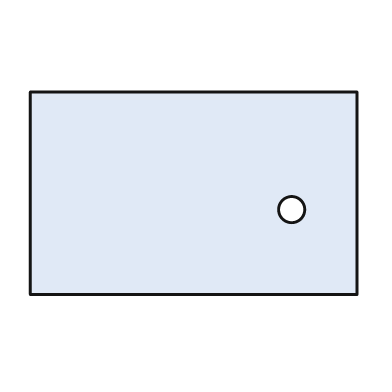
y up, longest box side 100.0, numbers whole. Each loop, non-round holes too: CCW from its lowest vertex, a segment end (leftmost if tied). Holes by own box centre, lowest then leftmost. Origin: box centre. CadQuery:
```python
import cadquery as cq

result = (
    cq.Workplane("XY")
    .moveTo(-50.0, -31.0)
    .lineTo(50.0, -31.0)
    .lineTo(50.0, 31.0)
    .lineTo(-50.0, 31.0)
    .close()
    .moveTo(30.0, -5.0)
    .circle(4.0)
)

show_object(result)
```